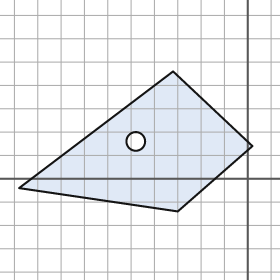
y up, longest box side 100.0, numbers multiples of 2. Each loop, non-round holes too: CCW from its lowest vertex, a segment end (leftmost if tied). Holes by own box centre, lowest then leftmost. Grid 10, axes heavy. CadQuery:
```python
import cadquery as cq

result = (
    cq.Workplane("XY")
    .moveTo(-30.0, -14.0)
    .lineTo(2.0, 14.0)
    .lineTo(-32.0, 46.0)
    .lineTo(-98.0, -4.0)
    .close()
    .moveTo(-48.0, 16.0)
    .circle(4.0)
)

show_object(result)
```